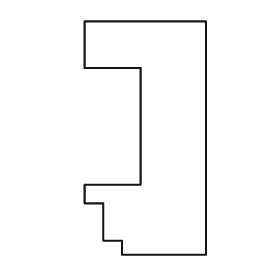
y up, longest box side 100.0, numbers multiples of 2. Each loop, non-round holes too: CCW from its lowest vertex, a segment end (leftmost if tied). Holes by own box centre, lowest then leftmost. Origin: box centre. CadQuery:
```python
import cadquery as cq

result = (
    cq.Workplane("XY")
    .moveTo(-10.0, -50.0)
    .lineTo(26.0, -50.0)
    .lineTo(26.0, 50.0)
    .lineTo(-26.0, 50.0)
    .lineTo(-26.0, 30.0)
    .lineTo(-2.0, 30.0)
    .lineTo(-2.0, -20.0)
    .lineTo(-26.0, -20.0)
    .lineTo(-26.0, -28.0)
    .lineTo(-18.0, -28.0)
    .lineTo(-18.0, -44.0)
    .lineTo(-10.0, -44.0)
    .close()
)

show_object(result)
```